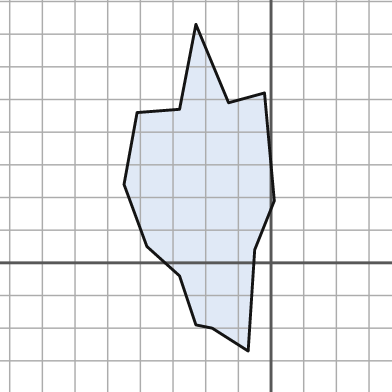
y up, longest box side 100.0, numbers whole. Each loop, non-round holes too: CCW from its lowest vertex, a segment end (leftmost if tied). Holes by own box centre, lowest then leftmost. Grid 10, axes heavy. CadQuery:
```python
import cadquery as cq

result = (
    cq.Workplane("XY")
    .moveTo(-7.0, -27.0)
    .lineTo(-5.0, 4.0)
    .lineTo(1.0, 19.0)
    .lineTo(-2.0, 52.0)
    .lineTo(-13.0, 49.0)
    .lineTo(-23.0, 73.0)
    .lineTo(-28.0, 47.0)
    .lineTo(-41.0, 46.0)
    .lineTo(-45.0, 24.0)
    .lineTo(-38.0, 5.0)
    .lineTo(-28.0, -4.0)
    .lineTo(-23.0, -19.0)
    .lineTo(-18.0, -20.0)
    .close()
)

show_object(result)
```